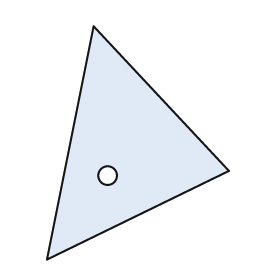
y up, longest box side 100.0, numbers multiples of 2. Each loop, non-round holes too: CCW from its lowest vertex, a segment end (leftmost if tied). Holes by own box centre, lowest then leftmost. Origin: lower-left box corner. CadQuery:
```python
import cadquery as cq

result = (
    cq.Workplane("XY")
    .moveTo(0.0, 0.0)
    .lineTo(78.0, 38.0)
    .lineTo(20.0, 100.0)
    .close()
    .moveTo(26.0, 36.0)
    .circle(4.0)
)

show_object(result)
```